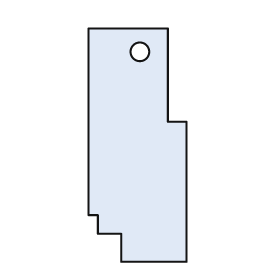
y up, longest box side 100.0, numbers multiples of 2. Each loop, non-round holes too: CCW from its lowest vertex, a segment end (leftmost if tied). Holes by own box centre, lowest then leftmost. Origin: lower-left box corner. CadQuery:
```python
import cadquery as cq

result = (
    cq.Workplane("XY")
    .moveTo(14.0, 0.0)
    .lineTo(42.0, 0.0)
    .lineTo(42.0, 60.0)
    .lineTo(34.0, 60.0)
    .lineTo(34.0, 100.0)
    .lineTo(0.0, 100.0)
    .lineTo(0.0, 20.0)
    .lineTo(4.0, 20.0)
    .lineTo(4.0, 12.0)
    .lineTo(14.0, 12.0)
    .close()
    .moveTo(22.0, 90.0)
    .circle(4.0)
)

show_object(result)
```